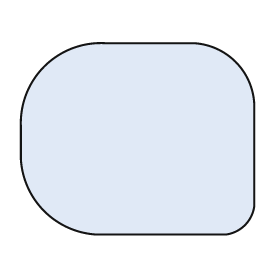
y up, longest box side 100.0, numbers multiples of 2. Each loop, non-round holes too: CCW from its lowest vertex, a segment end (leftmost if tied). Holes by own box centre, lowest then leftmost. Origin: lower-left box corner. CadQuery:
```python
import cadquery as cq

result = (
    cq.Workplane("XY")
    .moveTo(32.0, 0.0)
    .lineTo(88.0, 0.0)
    .threePointArc((96.0, 4.0), (100.0, 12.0))
    .lineTo(100.0, 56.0)
    .threePointArc((92.0, 74.0), (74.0, 82.0))
    .lineTo(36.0, 82.0)
    .threePointArc((10.0, 72.0), (0.0, 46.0))
    .lineTo(0.0, 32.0)
    .threePointArc((10.0, 10.0), (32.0, 0.0))
    .close()
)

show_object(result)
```